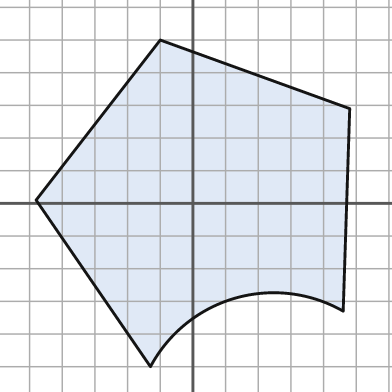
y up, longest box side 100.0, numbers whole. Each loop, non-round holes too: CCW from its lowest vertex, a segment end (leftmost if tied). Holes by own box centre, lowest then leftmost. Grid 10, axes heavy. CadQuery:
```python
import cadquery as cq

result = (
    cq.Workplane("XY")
    .moveTo(-13.0, -50.0)
    .threePointArc((13.0, -29.0), (46.0, -33.0))
    .lineTo(48.0, 29.0)
    .lineTo(-10.0, 50.0)
    .lineTo(-48.0, 1.0)
    .close()
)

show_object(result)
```